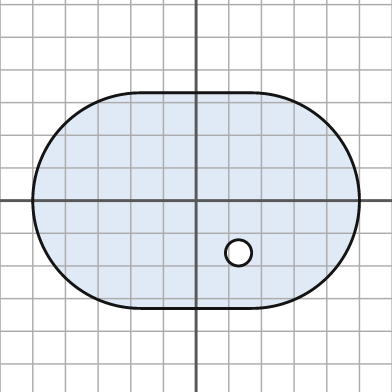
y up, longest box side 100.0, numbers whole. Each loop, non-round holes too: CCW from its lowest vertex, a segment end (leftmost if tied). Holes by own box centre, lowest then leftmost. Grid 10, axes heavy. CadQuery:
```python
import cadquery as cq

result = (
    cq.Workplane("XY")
    .moveTo(-17.0, -33.0)
    .lineTo(17.0, -33.0)
    .threePointArc((50.0, 0.0), (17.0, 33.0))
    .lineTo(-17.0, 33.0)
    .threePointArc((-50.0, 0.0), (-17.0, -33.0))
    .close()
    .moveTo(13.0, -16.0)
    .circle(4.0)
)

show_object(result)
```